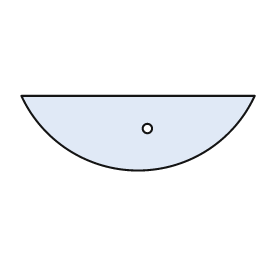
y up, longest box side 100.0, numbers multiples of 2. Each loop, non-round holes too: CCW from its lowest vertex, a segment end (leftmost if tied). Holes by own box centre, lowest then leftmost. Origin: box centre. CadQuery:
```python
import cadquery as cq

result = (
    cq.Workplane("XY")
    .moveTo(-50.0, 16.0)
    .threePointArc((0.0, -16.0), (50.0, 16.0))
    .close()
    .moveTo(4.0, 2.0)
    .circle(2.0)
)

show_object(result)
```